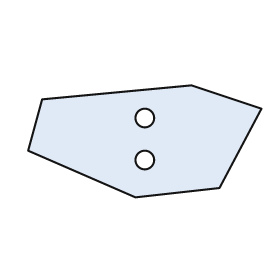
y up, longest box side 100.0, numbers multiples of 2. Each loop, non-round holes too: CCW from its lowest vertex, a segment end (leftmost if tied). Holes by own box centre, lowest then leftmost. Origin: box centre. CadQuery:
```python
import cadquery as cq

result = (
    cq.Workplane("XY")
    .moveTo(-4.0, -24.0)
    .lineTo(32.0, -20.0)
    .lineTo(50.0, 14.0)
    .lineTo(20.0, 24.0)
    .lineTo(-44.0, 18.0)
    .lineTo(-50.0, -4.0)
    .close()
    .moveTo(0.0, -8.0)
    .circle(4.0)
    .moveTo(0.0, 10.0)
    .circle(4.0)
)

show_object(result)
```